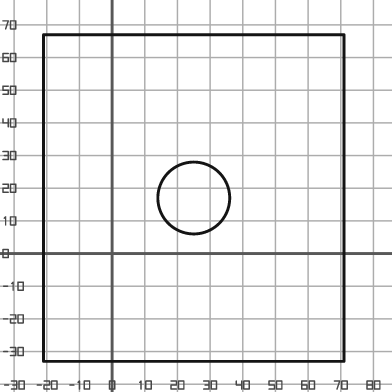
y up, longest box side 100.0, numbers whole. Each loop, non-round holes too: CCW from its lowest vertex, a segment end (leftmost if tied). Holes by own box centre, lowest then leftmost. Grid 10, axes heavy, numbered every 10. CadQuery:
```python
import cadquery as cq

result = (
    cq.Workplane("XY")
    .moveTo(-21.0, -33.0)
    .lineTo(71.0, -33.0)
    .lineTo(71.0, 67.0)
    .lineTo(-21.0, 67.0)
    .close()
    .moveTo(25.0, 17.0)
    .circle(11.0)
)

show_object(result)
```